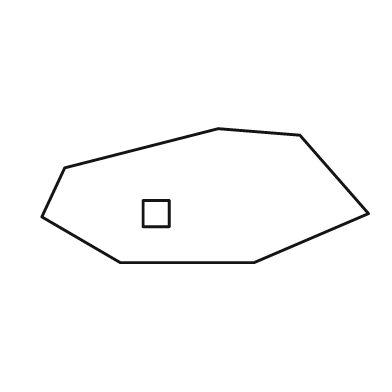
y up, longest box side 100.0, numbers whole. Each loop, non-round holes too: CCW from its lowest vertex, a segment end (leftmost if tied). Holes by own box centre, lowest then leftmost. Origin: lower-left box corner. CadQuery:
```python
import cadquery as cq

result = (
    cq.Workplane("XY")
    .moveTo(24.0, 0.0)
    .lineTo(65.0, 0.0)
    .lineTo(100.0, 15.0)
    .lineTo(79.0, 39.0)
    .lineTo(54.0, 41.0)
    .lineTo(7.0, 29.0)
    .lineTo(0.0, 14.0)
    .close()
    .moveTo(31.0, 11.0)
    .lineTo(39.0, 11.0)
    .lineTo(39.0, 19.0)
    .lineTo(31.0, 19.0)
    .close()
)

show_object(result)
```